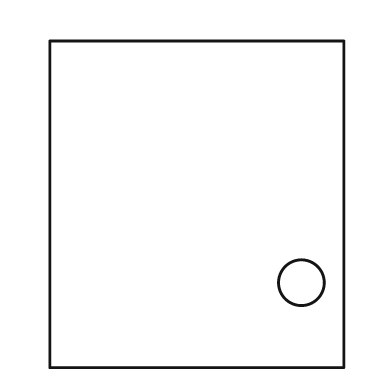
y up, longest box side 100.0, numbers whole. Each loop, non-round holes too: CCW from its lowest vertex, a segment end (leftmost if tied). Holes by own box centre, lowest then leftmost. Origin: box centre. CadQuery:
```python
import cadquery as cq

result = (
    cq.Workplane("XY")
    .moveTo(-45.0, -50.0)
    .lineTo(45.0, -50.0)
    .lineTo(45.0, 50.0)
    .lineTo(-45.0, 50.0)
    .close()
    .moveTo(32.0, -24.0)
    .circle(7.0)
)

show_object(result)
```